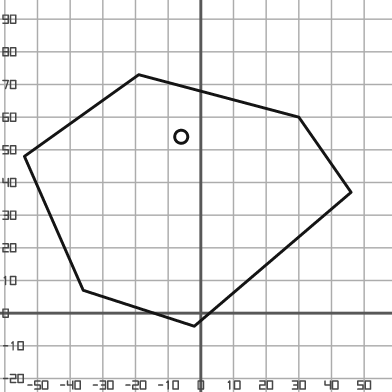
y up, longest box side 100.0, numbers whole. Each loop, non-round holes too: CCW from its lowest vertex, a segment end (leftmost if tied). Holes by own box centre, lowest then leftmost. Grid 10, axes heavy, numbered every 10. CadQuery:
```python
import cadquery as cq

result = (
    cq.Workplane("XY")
    .moveTo(-2.0, -4.0)
    .lineTo(46.0, 37.0)
    .lineTo(30.0, 60.0)
    .lineTo(-19.0, 73.0)
    .lineTo(-54.0, 48.0)
    .lineTo(-36.0, 7.0)
    .close()
    .moveTo(-6.0, 54.0)
    .circle(2.0)
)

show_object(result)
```